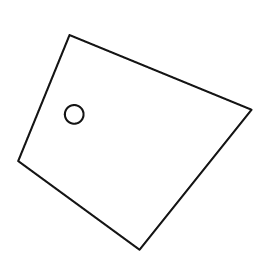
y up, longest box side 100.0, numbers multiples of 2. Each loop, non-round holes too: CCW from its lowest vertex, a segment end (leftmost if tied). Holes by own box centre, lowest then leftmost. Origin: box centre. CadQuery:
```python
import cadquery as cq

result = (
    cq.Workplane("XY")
    .moveTo(2.0, -46.0)
    .lineTo(50.0, 14.0)
    .lineTo(-28.0, 46.0)
    .lineTo(-50.0, -8.0)
    .close()
    .moveTo(-26.0, 12.0)
    .circle(4.0)
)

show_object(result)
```